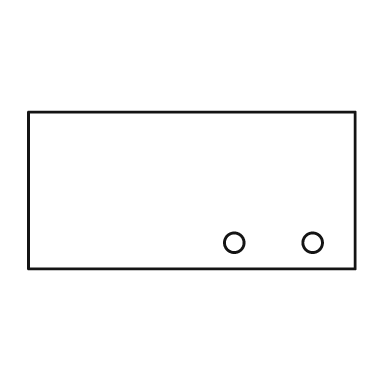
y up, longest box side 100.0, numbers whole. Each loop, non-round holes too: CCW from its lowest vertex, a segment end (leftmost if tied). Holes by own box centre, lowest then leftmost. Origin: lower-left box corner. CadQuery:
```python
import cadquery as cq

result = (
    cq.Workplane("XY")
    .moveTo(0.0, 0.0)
    .lineTo(100.0, 0.0)
    .lineTo(100.0, 48.0)
    .lineTo(0.0, 48.0)
    .close()
    .moveTo(63.0, 8.0)
    .circle(3.0)
    .moveTo(87.0, 8.0)
    .circle(3.0)
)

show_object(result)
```